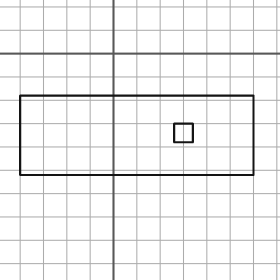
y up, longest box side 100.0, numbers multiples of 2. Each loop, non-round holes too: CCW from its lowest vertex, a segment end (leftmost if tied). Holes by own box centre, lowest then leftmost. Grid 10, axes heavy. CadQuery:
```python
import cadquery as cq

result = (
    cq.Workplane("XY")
    .moveTo(-40.0, -52.0)
    .lineTo(60.0, -52.0)
    .lineTo(60.0, -18.0)
    .lineTo(-40.0, -18.0)
    .close()
    .moveTo(26.0, -38.0)
    .lineTo(34.0, -38.0)
    .lineTo(34.0, -30.0)
    .lineTo(26.0, -30.0)
    .close()
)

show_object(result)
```